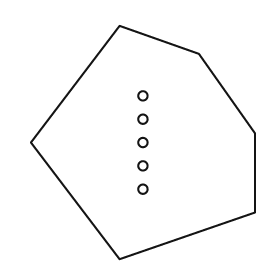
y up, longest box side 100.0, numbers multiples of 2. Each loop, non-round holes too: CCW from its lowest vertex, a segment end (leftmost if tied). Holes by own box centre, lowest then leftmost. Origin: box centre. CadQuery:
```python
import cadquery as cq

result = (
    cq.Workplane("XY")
    .moveTo(-10.0, -50.0)
    .lineTo(48.0, -30.0)
    .lineTo(48.0, 4.0)
    .lineTo(24.0, 38.0)
    .lineTo(-10.0, 50.0)
    .lineTo(-48.0, 0.0)
    .close()
    .moveTo(0.0, -20.0)
    .circle(2.0)
    .moveTo(0.0, -10.0)
    .circle(2.0)
    .moveTo(0.0, 0.0)
    .circle(2.0)
    .moveTo(0.0, 10.0)
    .circle(2.0)
    .moveTo(0.0, 20.0)
    .circle(2.0)
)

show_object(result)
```